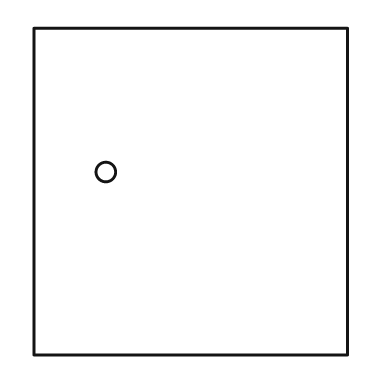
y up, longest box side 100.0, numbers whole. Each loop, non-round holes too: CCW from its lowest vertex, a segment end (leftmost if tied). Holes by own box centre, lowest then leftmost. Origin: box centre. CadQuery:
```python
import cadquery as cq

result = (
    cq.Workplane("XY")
    .moveTo(-48.0, -50.0)
    .lineTo(48.0, -50.0)
    .lineTo(48.0, 50.0)
    .lineTo(-48.0, 50.0)
    .close()
    .moveTo(-26.0, 6.0)
    .circle(3.0)
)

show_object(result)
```